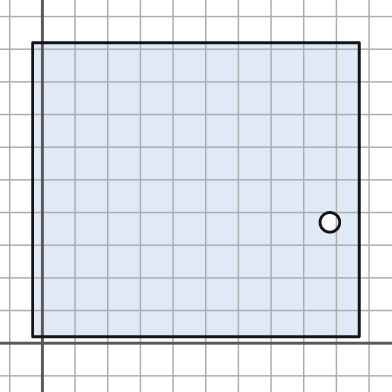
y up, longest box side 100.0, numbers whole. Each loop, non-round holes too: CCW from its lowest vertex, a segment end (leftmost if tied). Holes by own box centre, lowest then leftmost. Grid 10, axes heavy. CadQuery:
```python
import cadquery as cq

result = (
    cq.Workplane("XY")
    .moveTo(-3.0, 2.0)
    .lineTo(97.0, 2.0)
    .lineTo(97.0, 92.0)
    .lineTo(-3.0, 92.0)
    .close()
    .moveTo(88.0, 37.0)
    .circle(3.0)
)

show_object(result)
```